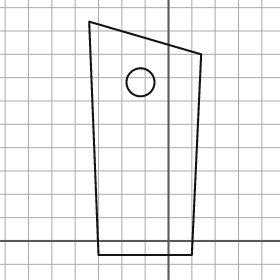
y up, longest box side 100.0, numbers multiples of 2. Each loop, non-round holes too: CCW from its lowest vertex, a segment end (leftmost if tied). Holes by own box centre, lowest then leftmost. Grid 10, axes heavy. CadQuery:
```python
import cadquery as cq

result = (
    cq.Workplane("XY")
    .moveTo(-30.0, -6.0)
    .lineTo(10.0, -6.0)
    .lineTo(14.0, 80.0)
    .lineTo(-34.0, 94.0)
    .close()
    .moveTo(-12.0, 68.0)
    .circle(6.0)
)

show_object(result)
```